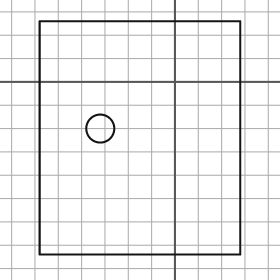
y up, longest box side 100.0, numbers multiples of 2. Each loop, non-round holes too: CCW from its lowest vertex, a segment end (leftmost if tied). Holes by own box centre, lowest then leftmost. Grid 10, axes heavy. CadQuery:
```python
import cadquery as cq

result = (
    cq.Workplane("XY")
    .moveTo(-58.0, -74.0)
    .lineTo(28.0, -74.0)
    .lineTo(28.0, 26.0)
    .lineTo(-58.0, 26.0)
    .close()
    .moveTo(-32.0, -20.0)
    .circle(6.0)
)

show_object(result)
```